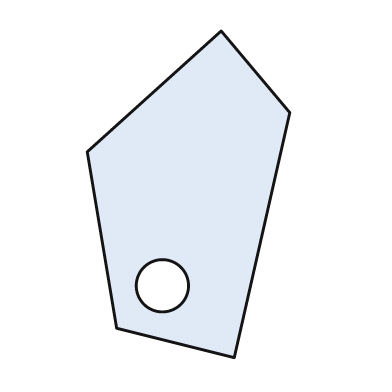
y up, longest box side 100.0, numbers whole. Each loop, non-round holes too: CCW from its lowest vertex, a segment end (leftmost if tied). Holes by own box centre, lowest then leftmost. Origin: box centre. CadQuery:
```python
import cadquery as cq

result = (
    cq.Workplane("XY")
    .moveTo(14.0, -50.0)
    .lineTo(31.0, 25.0)
    .lineTo(10.0, 50.0)
    .lineTo(-31.0, 13.0)
    .lineTo(-22.0, -41.0)
    .close()
    .moveTo(-8.0, -28.0)
    .circle(8.0)
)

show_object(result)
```